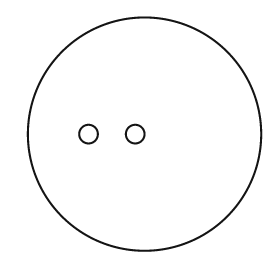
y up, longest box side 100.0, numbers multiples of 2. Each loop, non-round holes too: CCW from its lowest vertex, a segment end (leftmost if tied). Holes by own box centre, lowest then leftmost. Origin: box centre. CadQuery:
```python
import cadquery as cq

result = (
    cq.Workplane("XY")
    .moveTo(0.0, 0.0)
    .circle(50.0)
    .moveTo(-24.0, 0.0)
    .circle(4.0)
    .moveTo(-4.0, 0.0)
    .circle(4.0)
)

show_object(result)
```